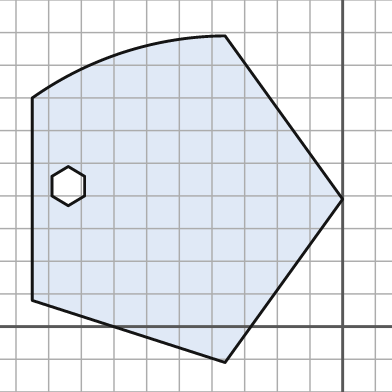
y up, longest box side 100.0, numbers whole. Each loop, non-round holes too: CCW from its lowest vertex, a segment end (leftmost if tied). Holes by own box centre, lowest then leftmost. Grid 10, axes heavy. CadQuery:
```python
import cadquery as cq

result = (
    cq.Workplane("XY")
    .moveTo(-36.0, -11.0)
    .lineTo(0.0, 39.0)
    .lineTo(-36.0, 89.0)
    .threePointArc((-67.0, 84.0), (-95.0, 70.0))
    .lineTo(-95.0, 8.0)
    .close()
    .moveTo(-84.0, 37.0)
    .lineTo(-79.0, 40.0)
    .lineTo(-79.0, 46.0)
    .lineTo(-84.0, 49.0)
    .lineTo(-89.0, 46.0)
    .lineTo(-89.0, 40.0)
    .close()
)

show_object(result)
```